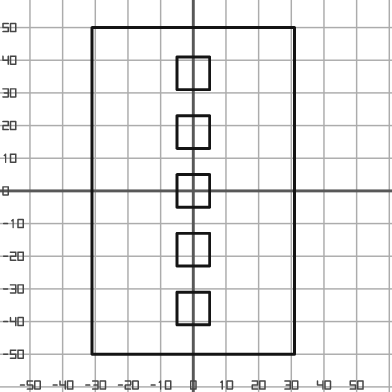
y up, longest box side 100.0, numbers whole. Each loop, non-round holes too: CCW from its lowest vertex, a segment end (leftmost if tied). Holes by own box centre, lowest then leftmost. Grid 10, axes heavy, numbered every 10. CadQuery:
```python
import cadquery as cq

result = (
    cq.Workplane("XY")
    .moveTo(-31.0, -50.0)
    .lineTo(31.0, -50.0)
    .lineTo(31.0, 50.0)
    .lineTo(-31.0, 50.0)
    .close()
    .moveTo(-5.0, -41.0)
    .lineTo(5.0, -41.0)
    .lineTo(5.0, -31.0)
    .lineTo(-5.0, -31.0)
    .close()
    .moveTo(-5.0, -23.0)
    .lineTo(5.0, -23.0)
    .lineTo(5.0, -13.0)
    .lineTo(-5.0, -13.0)
    .close()
    .moveTo(-5.0, -5.0)
    .lineTo(5.0, -5.0)
    .lineTo(5.0, 5.0)
    .lineTo(-5.0, 5.0)
    .close()
    .moveTo(-5.0, 13.0)
    .lineTo(5.0, 13.0)
    .lineTo(5.0, 23.0)
    .lineTo(-5.0, 23.0)
    .close()
    .moveTo(-5.0, 31.0)
    .lineTo(5.0, 31.0)
    .lineTo(5.0, 41.0)
    .lineTo(-5.0, 41.0)
    .close()
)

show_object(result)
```